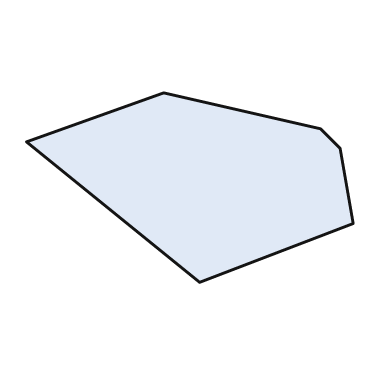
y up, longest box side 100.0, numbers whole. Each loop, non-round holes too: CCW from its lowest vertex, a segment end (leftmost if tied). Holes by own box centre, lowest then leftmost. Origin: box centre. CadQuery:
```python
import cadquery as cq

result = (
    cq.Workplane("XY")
    .moveTo(3.0, -29.0)
    .lineTo(50.0, -11.0)
    .lineTo(46.0, 12.0)
    .lineTo(40.0, 18.0)
    .lineTo(-8.0, 29.0)
    .lineTo(-50.0, 14.0)
    .close()
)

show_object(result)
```